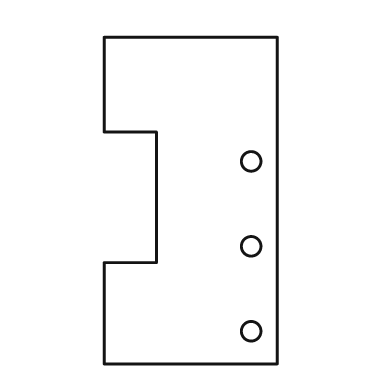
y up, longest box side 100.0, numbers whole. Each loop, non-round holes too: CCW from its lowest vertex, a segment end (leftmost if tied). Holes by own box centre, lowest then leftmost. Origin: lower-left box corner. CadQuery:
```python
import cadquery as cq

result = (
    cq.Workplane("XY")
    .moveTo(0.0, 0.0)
    .lineTo(53.0, 0.0)
    .lineTo(53.0, 100.0)
    .lineTo(0.0, 100.0)
    .lineTo(0.0, 71.0)
    .lineTo(16.0, 71.0)
    .lineTo(16.0, 31.0)
    .lineTo(0.0, 31.0)
    .close()
    .moveTo(45.0, 10.0)
    .circle(3.0)
    .moveTo(45.0, 36.0)
    .circle(3.0)
    .moveTo(45.0, 62.0)
    .circle(3.0)
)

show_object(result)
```